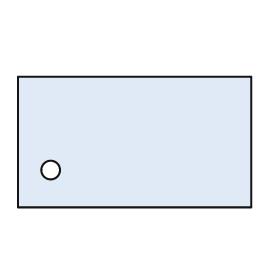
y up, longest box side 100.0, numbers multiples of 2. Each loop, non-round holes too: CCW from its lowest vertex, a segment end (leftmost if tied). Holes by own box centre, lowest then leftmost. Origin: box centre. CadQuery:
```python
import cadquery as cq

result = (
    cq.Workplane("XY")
    .moveTo(-50.0, -28.0)
    .lineTo(50.0, -28.0)
    .lineTo(50.0, 28.0)
    .lineTo(-50.0, 28.0)
    .close()
    .moveTo(-36.0, -12.0)
    .circle(4.0)
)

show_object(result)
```